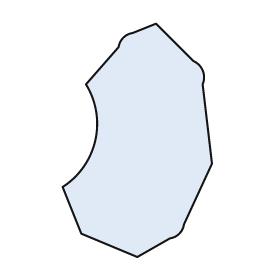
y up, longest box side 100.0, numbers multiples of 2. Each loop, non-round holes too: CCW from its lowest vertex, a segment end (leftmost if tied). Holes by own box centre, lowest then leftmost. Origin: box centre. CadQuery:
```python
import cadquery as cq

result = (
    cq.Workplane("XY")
    .moveTo(0.0, -50.0)
    .lineTo(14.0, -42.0)
    .threePointArc((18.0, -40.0), (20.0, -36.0))
    .lineTo(32.0, -10.0)
    .lineTo(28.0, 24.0)
    .threePointArc((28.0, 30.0), (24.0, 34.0))
    .lineTo(8.0, 50.0)
    .lineTo(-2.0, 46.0)
    .threePointArc((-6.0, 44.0), (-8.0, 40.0))
    .lineTo(-22.0, 24.0)
    .threePointArc((-18.0, 0.0), (-32.0, -20.0))
    .lineTo(-24.0, -40.0)
    .close()
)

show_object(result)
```